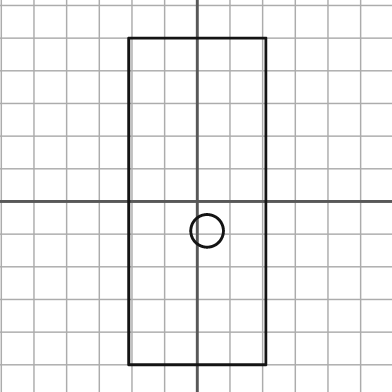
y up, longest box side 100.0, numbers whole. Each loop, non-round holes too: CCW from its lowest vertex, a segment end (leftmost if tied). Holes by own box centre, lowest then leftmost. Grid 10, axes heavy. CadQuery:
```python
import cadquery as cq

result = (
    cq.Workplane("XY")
    .moveTo(-21.0, -50.0)
    .lineTo(21.0, -50.0)
    .lineTo(21.0, 50.0)
    .lineTo(-21.0, 50.0)
    .close()
    .moveTo(3.0, -9.0)
    .circle(5.0)
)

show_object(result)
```